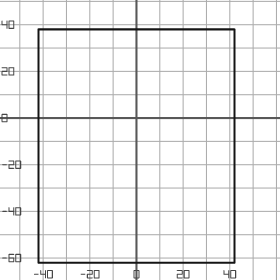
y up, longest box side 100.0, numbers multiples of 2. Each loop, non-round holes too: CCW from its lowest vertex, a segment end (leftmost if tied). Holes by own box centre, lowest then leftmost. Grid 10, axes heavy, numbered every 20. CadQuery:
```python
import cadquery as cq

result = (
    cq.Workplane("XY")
    .moveTo(-42.0, -62.0)
    .lineTo(42.0, -62.0)
    .lineTo(42.0, 38.0)
    .lineTo(-42.0, 38.0)
    .close()
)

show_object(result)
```